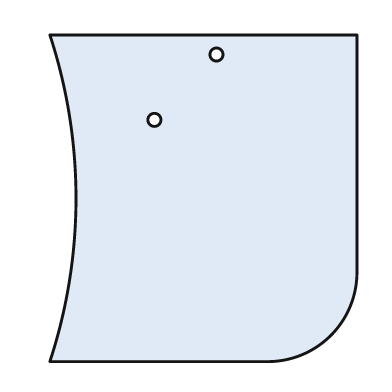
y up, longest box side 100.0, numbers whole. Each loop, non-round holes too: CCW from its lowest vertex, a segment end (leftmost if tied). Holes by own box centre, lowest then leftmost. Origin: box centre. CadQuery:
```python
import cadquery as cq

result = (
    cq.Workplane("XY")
    .moveTo(-47.0, -50.0)
    .lineTo(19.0, -50.0)
    .threePointArc((39.0, -42.0), (47.0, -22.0))
    .lineTo(47.0, 50.0)
    .lineTo(-47.0, 50.0)
    .threePointArc((-39.0, 0.0), (-47.0, -50.0))
    .close()
    .moveTo(-15.0, 24.0)
    .circle(2.0)
    .moveTo(4.0, 44.0)
    .circle(2.0)
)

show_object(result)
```